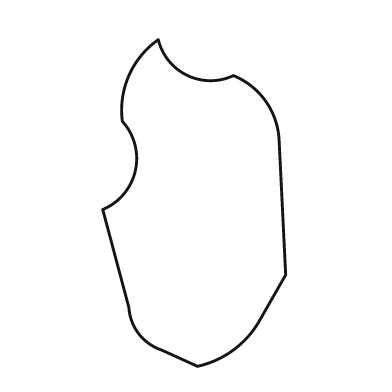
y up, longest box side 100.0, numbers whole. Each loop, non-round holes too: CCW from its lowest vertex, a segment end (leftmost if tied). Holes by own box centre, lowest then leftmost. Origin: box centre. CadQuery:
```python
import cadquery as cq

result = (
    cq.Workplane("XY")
    .moveTo(1.0, -50.0)
    .threePointArc((12.0, -45.0), (20.0, -36.0))
    .lineTo(28.0, -22.0)
    .lineTo(26.0, 19.0)
    .threePointArc((22.0, 31.0), (12.0, 39.0))
    .threePointArc((-2.0, 39.0), (-11.0, 50.0))
    .threePointArc((-20.0, 39.0), (-22.0, 25.0))
    .threePointArc((-18.0, 10.0), (-28.0, -2.0))
    .lineTo(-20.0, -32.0)
    .threePointArc((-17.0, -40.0), (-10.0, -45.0))
    .close()
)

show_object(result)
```